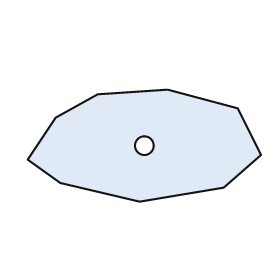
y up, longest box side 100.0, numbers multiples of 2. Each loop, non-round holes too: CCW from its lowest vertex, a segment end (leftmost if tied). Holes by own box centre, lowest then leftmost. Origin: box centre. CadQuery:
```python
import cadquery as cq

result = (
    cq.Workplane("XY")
    .moveTo(-2.0, -24.0)
    .lineTo(34.0, -18.0)
    .lineTo(50.0, -4.0)
    .lineTo(40.0, 16.0)
    .lineTo(10.0, 24.0)
    .lineTo(-20.0, 22.0)
    .lineTo(-38.0, 12.0)
    .lineTo(-50.0, -6.0)
    .lineTo(-36.0, -16.0)
    .close()
    .moveTo(0.0, 0.0)
    .circle(4.0)
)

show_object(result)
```